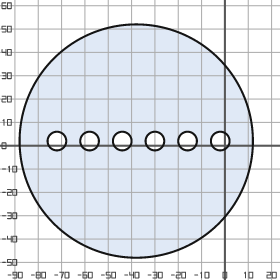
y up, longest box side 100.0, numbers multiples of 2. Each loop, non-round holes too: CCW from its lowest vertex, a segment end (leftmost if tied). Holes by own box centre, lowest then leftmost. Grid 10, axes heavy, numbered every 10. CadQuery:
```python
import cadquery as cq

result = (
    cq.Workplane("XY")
    .moveTo(-38.0, 2.0)
    .circle(50.0)
    .moveTo(-72.0, 2.0)
    .circle(4.0)
    .moveTo(-58.0, 2.0)
    .circle(4.0)
    .moveTo(-44.0, 2.0)
    .circle(4.0)
    .moveTo(-30.0, 2.0)
    .circle(4.0)
    .moveTo(-16.0, 2.0)
    .circle(4.0)
    .moveTo(-2.0, 2.0)
    .circle(4.0)
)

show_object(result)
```